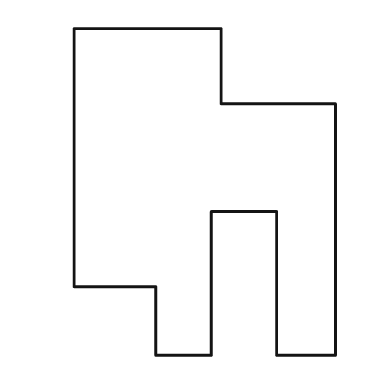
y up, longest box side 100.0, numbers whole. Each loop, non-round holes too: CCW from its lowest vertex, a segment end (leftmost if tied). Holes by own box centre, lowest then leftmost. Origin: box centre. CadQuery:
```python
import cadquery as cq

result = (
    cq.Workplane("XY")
    .moveTo(-15.0, -50.0)
    .lineTo(2.0, -50.0)
    .lineTo(2.0, -6.0)
    .lineTo(22.0, -6.0)
    .lineTo(22.0, -50.0)
    .lineTo(40.0, -50.0)
    .lineTo(40.0, 27.0)
    .lineTo(5.0, 27.0)
    .lineTo(5.0, 50.0)
    .lineTo(-40.0, 50.0)
    .lineTo(-40.0, -29.0)
    .lineTo(-15.0, -29.0)
    .close()
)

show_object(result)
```